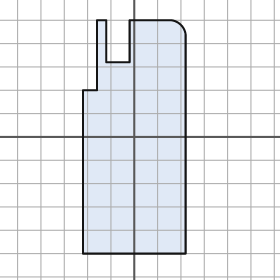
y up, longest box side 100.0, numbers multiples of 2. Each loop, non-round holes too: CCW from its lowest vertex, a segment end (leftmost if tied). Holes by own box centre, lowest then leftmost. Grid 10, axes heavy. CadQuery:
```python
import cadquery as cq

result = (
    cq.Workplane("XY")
    .moveTo(-22.0, -50.0)
    .lineTo(22.0, -50.0)
    .lineTo(22.0, 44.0)
    .threePointArc((20.0, 48.0), (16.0, 50.0))
    .lineTo(-2.0, 50.0)
    .lineTo(-2.0, 32.0)
    .lineTo(-12.0, 32.0)
    .lineTo(-12.0, 50.0)
    .lineTo(-16.0, 50.0)
    .lineTo(-16.0, 20.0)
    .lineTo(-22.0, 20.0)
    .close()
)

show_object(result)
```